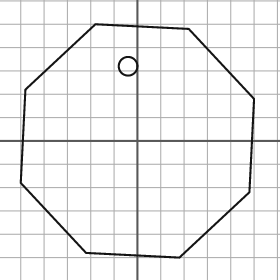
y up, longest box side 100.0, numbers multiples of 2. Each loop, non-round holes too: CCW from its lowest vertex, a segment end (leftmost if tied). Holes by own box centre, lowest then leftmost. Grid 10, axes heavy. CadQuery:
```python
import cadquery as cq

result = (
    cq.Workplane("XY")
    .moveTo(18.0, -50.0)
    .lineTo(48.0, -22.0)
    .lineTo(50.0, 18.0)
    .lineTo(22.0, 48.0)
    .lineTo(-18.0, 50.0)
    .lineTo(-48.0, 22.0)
    .lineTo(-50.0, -18.0)
    .lineTo(-22.0, -48.0)
    .close()
    .moveTo(-4.0, 32.0)
    .circle(4.0)
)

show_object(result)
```